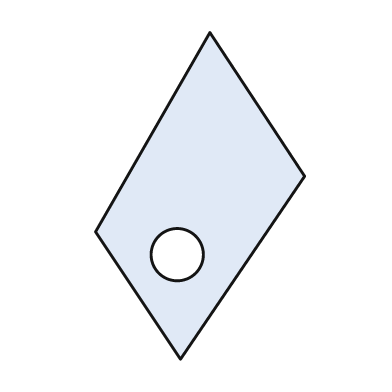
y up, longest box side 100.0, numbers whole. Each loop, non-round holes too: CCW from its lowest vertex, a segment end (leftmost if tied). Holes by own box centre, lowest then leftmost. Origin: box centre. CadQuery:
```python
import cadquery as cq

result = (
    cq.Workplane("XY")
    .moveTo(-6.0, -50.0)
    .lineTo(32.0, 6.0)
    .lineTo(3.0, 50.0)
    .lineTo(-32.0, -11.0)
    .close()
    .moveTo(-7.0, -18.0)
    .circle(8.0)
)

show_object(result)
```